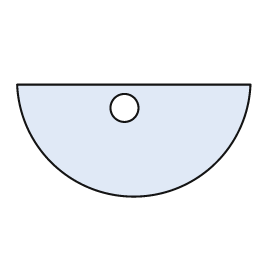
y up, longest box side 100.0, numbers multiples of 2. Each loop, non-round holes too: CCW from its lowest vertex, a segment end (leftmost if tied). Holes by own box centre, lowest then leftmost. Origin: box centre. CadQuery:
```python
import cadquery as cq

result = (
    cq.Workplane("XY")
    .moveTo(-50.0, 24.0)
    .threePointArc((0.0, -24.0), (50.0, 24.0))
    .close()
    .moveTo(-4.0, 14.0)
    .circle(6.0)
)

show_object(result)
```